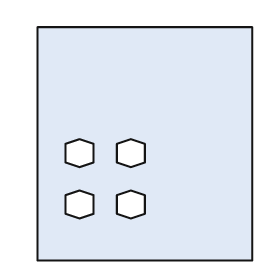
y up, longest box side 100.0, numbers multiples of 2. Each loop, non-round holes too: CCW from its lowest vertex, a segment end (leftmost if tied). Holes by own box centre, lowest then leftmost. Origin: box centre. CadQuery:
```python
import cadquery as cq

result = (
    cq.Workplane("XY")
    .moveTo(-46.0, -50.0)
    .lineTo(46.0, -50.0)
    .lineTo(46.0, 50.0)
    .lineTo(-46.0, 50.0)
    .close()
    .moveTo(-28.0, -32.0)
    .lineTo(-22.0, -30.0)
    .lineTo(-22.0, -22.0)
    .lineTo(-28.0, -20.0)
    .lineTo(-34.0, -22.0)
    .lineTo(-34.0, -30.0)
    .close()
    .moveTo(-6.0, -32.0)
    .lineTo(0.0, -30.0)
    .lineTo(0.0, -22.0)
    .lineTo(-6.0, -20.0)
    .lineTo(-12.0, -22.0)
    .lineTo(-12.0, -30.0)
    .close()
    .moveTo(-28.0, -10.0)
    .lineTo(-22.0, -8.0)
    .lineTo(-22.0, 0.0)
    .lineTo(-28.0, 2.0)
    .lineTo(-34.0, 0.0)
    .lineTo(-34.0, -8.0)
    .close()
    .moveTo(-6.0, -10.0)
    .lineTo(0.0, -8.0)
    .lineTo(0.0, 0.0)
    .lineTo(-6.0, 2.0)
    .lineTo(-12.0, 0.0)
    .lineTo(-12.0, -8.0)
    .close()
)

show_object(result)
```